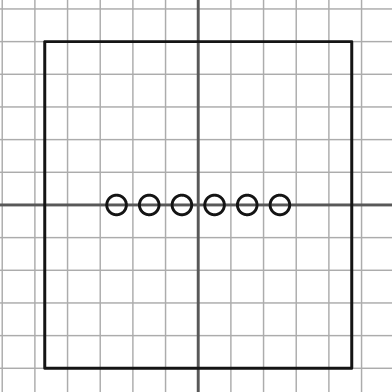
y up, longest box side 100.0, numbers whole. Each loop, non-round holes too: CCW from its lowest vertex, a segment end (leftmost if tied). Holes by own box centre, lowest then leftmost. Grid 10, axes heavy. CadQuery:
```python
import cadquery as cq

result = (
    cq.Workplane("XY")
    .moveTo(-47.0, -50.0)
    .lineTo(47.0, -50.0)
    .lineTo(47.0, 50.0)
    .lineTo(-47.0, 50.0)
    .close()
    .moveTo(-25.0, 0.0)
    .circle(3.0)
    .moveTo(-15.0, 0.0)
    .circle(3.0)
    .moveTo(-5.0, 0.0)
    .circle(3.0)
    .moveTo(5.0, 0.0)
    .circle(3.0)
    .moveTo(15.0, 0.0)
    .circle(3.0)
    .moveTo(25.0, 0.0)
    .circle(3.0)
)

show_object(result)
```